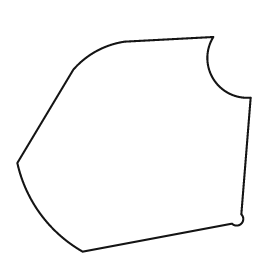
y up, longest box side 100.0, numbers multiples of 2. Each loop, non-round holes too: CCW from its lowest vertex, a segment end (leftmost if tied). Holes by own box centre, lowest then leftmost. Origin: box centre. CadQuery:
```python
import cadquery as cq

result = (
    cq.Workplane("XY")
    .moveTo(-22.0, -46.0)
    .lineTo(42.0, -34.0)
    .threePointArc((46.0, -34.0), (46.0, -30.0))
    .lineTo(50.0, 20.0)
    .threePointArc((34.0, 28.0), (34.0, 46.0))
    .lineTo(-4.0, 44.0)
    .threePointArc((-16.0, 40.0), (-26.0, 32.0))
    .lineTo(-50.0, -8.0)
    .threePointArc((-40.0, -30.0), (-22.0, -46.0))
    .close()
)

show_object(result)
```